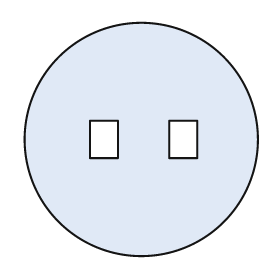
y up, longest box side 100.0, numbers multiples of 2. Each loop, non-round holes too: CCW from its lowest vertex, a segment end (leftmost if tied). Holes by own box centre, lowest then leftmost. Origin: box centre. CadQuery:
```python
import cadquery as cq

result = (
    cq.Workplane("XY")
    .moveTo(0.0, 0.0)
    .circle(50.0)
    .moveTo(-22.0, -8.0)
    .lineTo(-10.0, -8.0)
    .lineTo(-10.0, 8.0)
    .lineTo(-22.0, 8.0)
    .close()
    .moveTo(12.0, -8.0)
    .lineTo(24.0, -8.0)
    .lineTo(24.0, 8.0)
    .lineTo(12.0, 8.0)
    .close()
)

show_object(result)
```